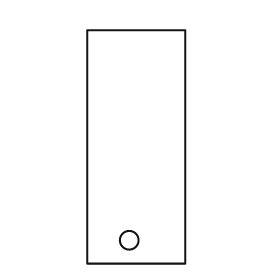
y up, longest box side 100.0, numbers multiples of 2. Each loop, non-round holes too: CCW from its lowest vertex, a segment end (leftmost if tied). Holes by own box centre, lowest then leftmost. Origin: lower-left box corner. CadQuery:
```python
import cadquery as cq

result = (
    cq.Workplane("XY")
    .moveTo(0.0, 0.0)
    .lineTo(42.0, 0.0)
    .lineTo(42.0, 100.0)
    .lineTo(0.0, 100.0)
    .close()
    .moveTo(18.0, 10.0)
    .circle(4.0)
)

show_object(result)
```